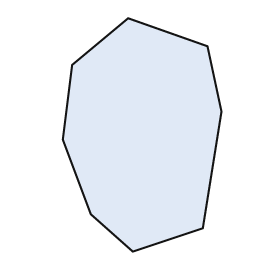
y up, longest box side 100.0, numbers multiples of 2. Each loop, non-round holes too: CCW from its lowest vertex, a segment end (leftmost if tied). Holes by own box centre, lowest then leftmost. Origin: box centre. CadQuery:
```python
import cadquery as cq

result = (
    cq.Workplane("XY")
    .moveTo(-4.0, -50.0)
    .lineTo(26.0, -40.0)
    .lineTo(34.0, 10.0)
    .lineTo(28.0, 38.0)
    .lineTo(-6.0, 50.0)
    .lineTo(-30.0, 30.0)
    .lineTo(-34.0, -2.0)
    .lineTo(-22.0, -34.0)
    .close()
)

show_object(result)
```